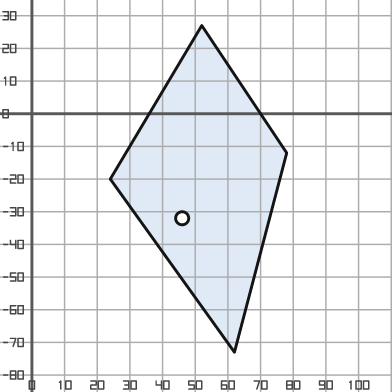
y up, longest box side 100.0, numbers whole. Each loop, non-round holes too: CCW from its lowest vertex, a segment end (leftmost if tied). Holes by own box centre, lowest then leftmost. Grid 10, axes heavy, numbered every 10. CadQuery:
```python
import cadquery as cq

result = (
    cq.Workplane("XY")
    .moveTo(62.0, -73.0)
    .lineTo(78.0, -12.0)
    .lineTo(52.0, 27.0)
    .lineTo(24.0, -20.0)
    .close()
    .moveTo(46.0, -32.0)
    .circle(2.0)
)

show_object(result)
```